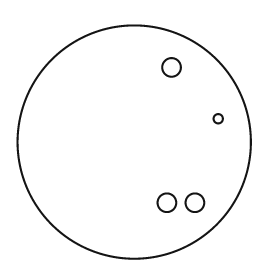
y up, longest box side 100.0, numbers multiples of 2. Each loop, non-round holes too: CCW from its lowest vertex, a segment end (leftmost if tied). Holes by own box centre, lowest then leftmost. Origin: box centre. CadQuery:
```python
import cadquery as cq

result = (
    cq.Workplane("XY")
    .moveTo(0.0, 0.0)
    .circle(50.0)
    .moveTo(14.0, -26.0)
    .circle(4.0)
    .moveTo(26.0, -26.0)
    .circle(4.0)
    .moveTo(36.0, 10.0)
    .circle(2.0)
    .moveTo(16.0, 32.0)
    .circle(4.0)
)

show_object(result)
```